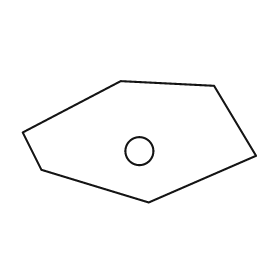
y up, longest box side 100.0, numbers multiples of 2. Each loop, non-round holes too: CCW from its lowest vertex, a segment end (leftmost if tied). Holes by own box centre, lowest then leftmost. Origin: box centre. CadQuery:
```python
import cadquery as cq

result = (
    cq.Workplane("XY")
    .moveTo(4.0, -26.0)
    .lineTo(50.0, -6.0)
    .lineTo(32.0, 24.0)
    .lineTo(-8.0, 26.0)
    .lineTo(-50.0, 4.0)
    .lineTo(-42.0, -12.0)
    .close()
    .moveTo(0.0, -4.0)
    .circle(6.0)
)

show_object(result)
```